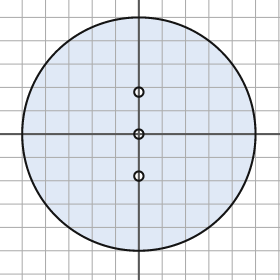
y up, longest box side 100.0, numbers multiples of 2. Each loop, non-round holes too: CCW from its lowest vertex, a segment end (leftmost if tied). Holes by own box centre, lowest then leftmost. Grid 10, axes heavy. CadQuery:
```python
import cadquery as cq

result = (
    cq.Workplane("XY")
    .moveTo(0.0, 0.0)
    .circle(50.0)
    .moveTo(0.0, -18.0)
    .circle(2.0)
    .moveTo(0.0, 0.0)
    .circle(2.0)
    .moveTo(0.0, 18.0)
    .circle(2.0)
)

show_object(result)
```